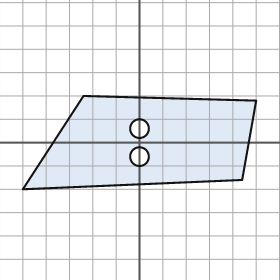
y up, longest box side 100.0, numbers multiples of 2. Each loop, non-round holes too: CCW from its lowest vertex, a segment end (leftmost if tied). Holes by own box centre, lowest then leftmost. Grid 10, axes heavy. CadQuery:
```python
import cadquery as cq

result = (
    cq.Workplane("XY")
    .moveTo(-50.0, -20.0)
    .lineTo(44.0, -16.0)
    .lineTo(50.0, 18.0)
    .lineTo(-24.0, 20.0)
    .close()
    .moveTo(0.0, -6.0)
    .circle(4.0)
    .moveTo(0.0, 6.0)
    .circle(4.0)
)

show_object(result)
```